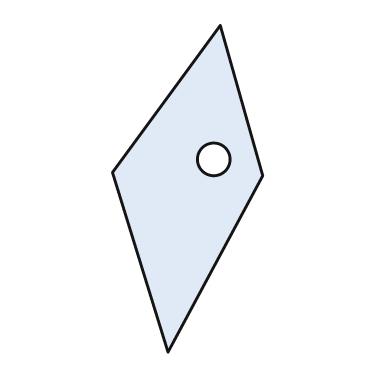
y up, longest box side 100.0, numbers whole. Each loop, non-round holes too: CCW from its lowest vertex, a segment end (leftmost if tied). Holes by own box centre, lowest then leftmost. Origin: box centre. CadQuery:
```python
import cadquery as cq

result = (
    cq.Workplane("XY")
    .moveTo(-6.0, -50.0)
    .lineTo(23.0, 4.0)
    .lineTo(10.0, 50.0)
    .lineTo(-23.0, 5.0)
    .close()
    .moveTo(8.0, 9.0)
    .circle(5.0)
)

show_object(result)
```